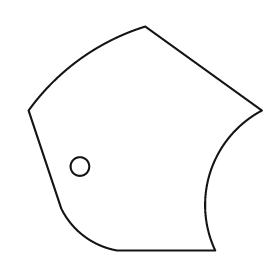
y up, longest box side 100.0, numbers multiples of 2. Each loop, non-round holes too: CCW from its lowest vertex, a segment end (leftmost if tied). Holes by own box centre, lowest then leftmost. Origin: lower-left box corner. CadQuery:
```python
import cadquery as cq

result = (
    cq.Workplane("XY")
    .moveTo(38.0, 0.0)
    .lineTo(80.0, 0.0)
    .threePointArc((78.0, 34.0), (100.0, 60.0))
    .lineTo(50.0, 96.0)
    .threePointArc((22.0, 82.0), (0.0, 60.0))
    .lineTo(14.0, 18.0)
    .threePointArc((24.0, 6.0), (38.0, 0.0))
    .close()
    .moveTo(22.0, 36.0)
    .circle(4.0)
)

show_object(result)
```